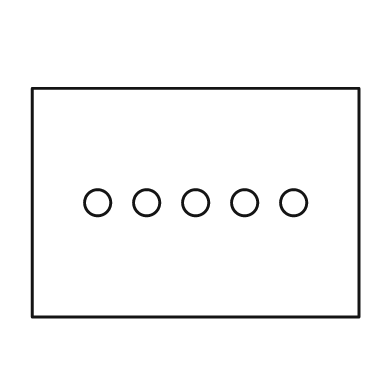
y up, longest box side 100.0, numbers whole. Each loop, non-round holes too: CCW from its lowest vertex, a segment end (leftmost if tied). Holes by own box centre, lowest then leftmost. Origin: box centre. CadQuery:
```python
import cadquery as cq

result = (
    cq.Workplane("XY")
    .moveTo(-50.0, -35.0)
    .lineTo(50.0, -35.0)
    .lineTo(50.0, 35.0)
    .lineTo(-50.0, 35.0)
    .close()
    .moveTo(-30.0, 0.0)
    .circle(4.0)
    .moveTo(-15.0, 0.0)
    .circle(4.0)
    .moveTo(0.0, 0.0)
    .circle(4.0)
    .moveTo(15.0, 0.0)
    .circle(4.0)
    .moveTo(30.0, 0.0)
    .circle(4.0)
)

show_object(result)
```